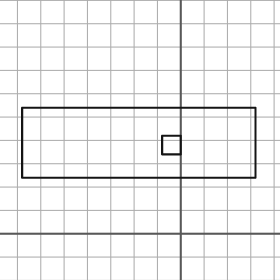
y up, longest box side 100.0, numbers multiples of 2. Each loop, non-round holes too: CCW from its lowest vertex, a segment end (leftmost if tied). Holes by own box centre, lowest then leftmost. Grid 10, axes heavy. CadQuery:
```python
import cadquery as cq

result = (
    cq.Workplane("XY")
    .moveTo(-68.0, 24.0)
    .lineTo(32.0, 24.0)
    .lineTo(32.0, 54.0)
    .lineTo(-68.0, 54.0)
    .close()
    .moveTo(-8.0, 34.0)
    .lineTo(0.0, 34.0)
    .lineTo(0.0, 42.0)
    .lineTo(-8.0, 42.0)
    .close()
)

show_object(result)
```